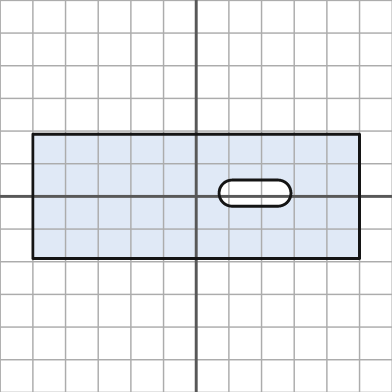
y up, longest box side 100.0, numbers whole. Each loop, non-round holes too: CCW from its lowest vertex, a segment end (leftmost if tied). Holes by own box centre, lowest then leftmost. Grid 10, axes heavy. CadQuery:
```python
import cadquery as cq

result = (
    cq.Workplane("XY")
    .moveTo(-50.0, -19.0)
    .lineTo(50.0, -19.0)
    .lineTo(50.0, 19.0)
    .lineTo(-50.0, 19.0)
    .close()
    .moveTo(11.0, -3.0)
    .lineTo(25.0, -3.0)
    .threePointArc((29.0, 1.0), (25.0, 5.0))
    .lineTo(11.0, 5.0)
    .threePointArc((7.0, 1.0), (11.0, -3.0))
    .close()
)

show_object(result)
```